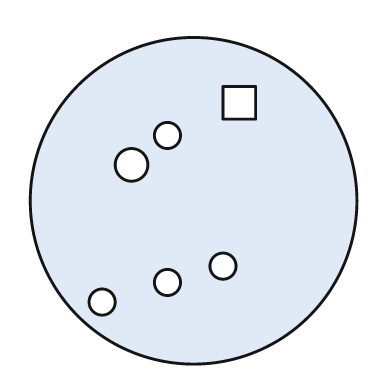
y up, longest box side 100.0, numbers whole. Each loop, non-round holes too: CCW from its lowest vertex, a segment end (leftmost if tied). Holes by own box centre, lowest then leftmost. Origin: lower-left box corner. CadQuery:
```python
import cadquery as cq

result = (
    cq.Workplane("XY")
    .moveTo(50.0, 50.0)
    .circle(50.0)
    .moveTo(22.0, 19.0)
    .circle(4.0)
    .moveTo(42.0, 25.0)
    .circle(4.0)
    .moveTo(59.0, 30.0)
    .circle(4.0)
    .moveTo(31.0, 61.0)
    .circle(5.0)
    .moveTo(42.0, 70.0)
    .circle(4.0)
    .moveTo(59.0, 75.0)
    .lineTo(69.0, 75.0)
    .lineTo(69.0, 85.0)
    .lineTo(59.0, 85.0)
    .close()
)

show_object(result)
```